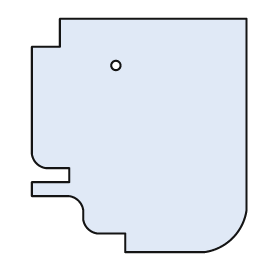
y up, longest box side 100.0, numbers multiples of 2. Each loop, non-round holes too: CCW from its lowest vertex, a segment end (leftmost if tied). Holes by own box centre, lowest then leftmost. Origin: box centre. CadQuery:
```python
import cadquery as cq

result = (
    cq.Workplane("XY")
    .moveTo(-6.0, -50.0)
    .lineTo(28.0, -50.0)
    .threePointArc((40.0, -44.0), (46.0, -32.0))
    .lineTo(46.0, 50.0)
    .lineTo(-34.0, 50.0)
    .lineTo(-34.0, 38.0)
    .lineTo(-46.0, 38.0)
    .lineTo(-46.0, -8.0)
    .threePointArc((-44.0, -12.0), (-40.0, -14.0))
    .lineTo(-30.0, -14.0)
    .lineTo(-30.0, -20.0)
    .lineTo(-46.0, -20.0)
    .lineTo(-46.0, -26.0)
    .lineTo(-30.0, -26.0)
    .threePointArc((-26.0, -28.0), (-24.0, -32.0))
    .lineTo(-24.0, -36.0)
    .threePointArc((-22.0, -40.0), (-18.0, -42.0))
    .lineTo(-6.0, -42.0)
    .close()
    .moveTo(-10.0, 30.0)
    .circle(2.0)
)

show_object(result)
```